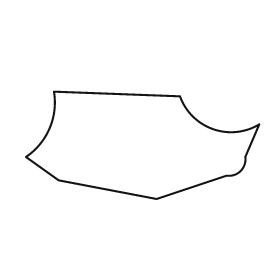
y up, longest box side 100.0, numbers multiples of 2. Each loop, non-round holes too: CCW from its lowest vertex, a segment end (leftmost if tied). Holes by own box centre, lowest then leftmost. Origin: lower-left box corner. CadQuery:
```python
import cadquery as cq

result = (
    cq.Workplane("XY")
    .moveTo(56.0, 0.0)
    .lineTo(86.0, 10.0)
    .threePointArc((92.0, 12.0), (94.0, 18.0))
    .lineTo(100.0, 32.0)
    .threePointArc((80.0, 30.0), (66.0, 44.0))
    .lineTo(12.0, 46.0)
    .threePointArc((10.0, 30.0), (0.0, 18.0))
    .lineTo(14.0, 8.0)
    .close()
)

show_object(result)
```